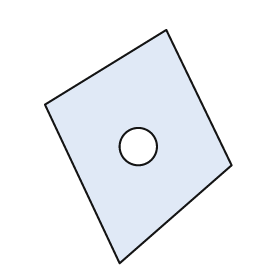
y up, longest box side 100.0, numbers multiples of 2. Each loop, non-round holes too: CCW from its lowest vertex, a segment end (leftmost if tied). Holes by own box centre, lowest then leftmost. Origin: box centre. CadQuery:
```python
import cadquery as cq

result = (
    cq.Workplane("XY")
    .moveTo(-8.0, -50.0)
    .lineTo(40.0, -8.0)
    .lineTo(12.0, 50.0)
    .lineTo(-40.0, 18.0)
    .close()
    .moveTo(0.0, 0.0)
    .circle(8.0)
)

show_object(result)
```